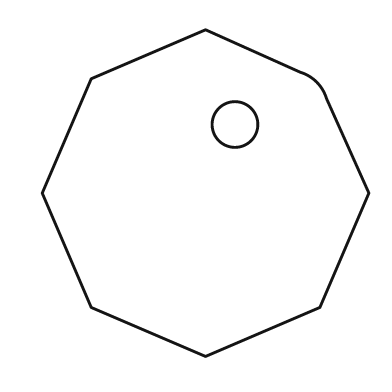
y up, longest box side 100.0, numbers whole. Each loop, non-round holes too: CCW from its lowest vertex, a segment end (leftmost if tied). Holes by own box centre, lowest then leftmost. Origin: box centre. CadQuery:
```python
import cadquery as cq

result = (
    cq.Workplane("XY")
    .moveTo(0.0, -50.0)
    .lineTo(35.0, -35.0)
    .lineTo(50.0, 0.0)
    .lineTo(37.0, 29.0)
    .threePointArc((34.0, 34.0), (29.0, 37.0))
    .lineTo(0.0, 50.0)
    .lineTo(-35.0, 35.0)
    .lineTo(-50.0, 0.0)
    .lineTo(-35.0, -35.0)
    .close()
    .moveTo(9.0, 21.0)
    .circle(7.0)
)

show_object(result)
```